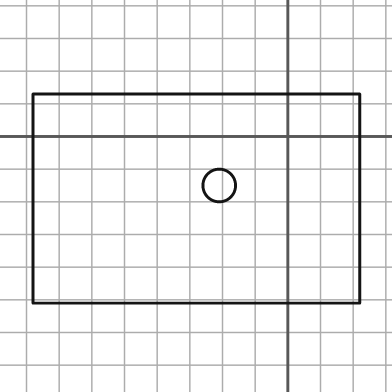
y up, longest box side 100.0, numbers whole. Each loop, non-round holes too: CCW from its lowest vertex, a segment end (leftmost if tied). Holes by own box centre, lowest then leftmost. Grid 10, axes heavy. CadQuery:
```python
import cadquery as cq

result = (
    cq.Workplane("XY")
    .moveTo(-78.0, -51.0)
    .lineTo(22.0, -51.0)
    .lineTo(22.0, 13.0)
    .lineTo(-78.0, 13.0)
    .close()
    .moveTo(-21.0, -15.0)
    .circle(5.0)
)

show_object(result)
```